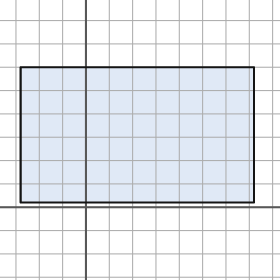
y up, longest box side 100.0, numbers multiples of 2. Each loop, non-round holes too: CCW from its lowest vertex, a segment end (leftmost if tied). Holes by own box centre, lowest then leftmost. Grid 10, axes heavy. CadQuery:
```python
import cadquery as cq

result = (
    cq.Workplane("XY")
    .moveTo(-28.0, 2.0)
    .lineTo(72.0, 2.0)
    .lineTo(72.0, 60.0)
    .lineTo(-28.0, 60.0)
    .close()
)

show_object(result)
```